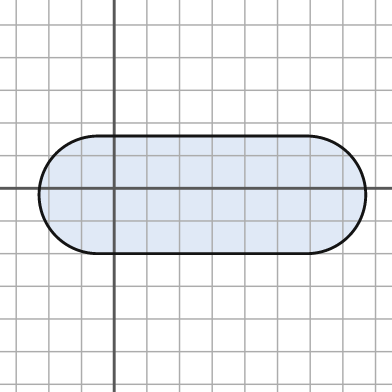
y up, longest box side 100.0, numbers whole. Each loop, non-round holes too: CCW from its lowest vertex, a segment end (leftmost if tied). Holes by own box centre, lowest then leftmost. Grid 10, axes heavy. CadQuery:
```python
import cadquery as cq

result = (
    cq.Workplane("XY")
    .moveTo(-5.0, -20.0)
    .lineTo(59.0, -20.0)
    .threePointArc((77.0, -2.0), (59.0, 16.0))
    .lineTo(-5.0, 16.0)
    .threePointArc((-23.0, -2.0), (-5.0, -20.0))
    .close()
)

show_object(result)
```